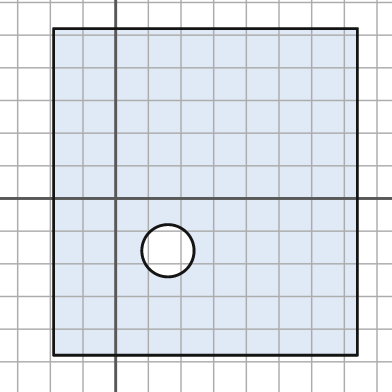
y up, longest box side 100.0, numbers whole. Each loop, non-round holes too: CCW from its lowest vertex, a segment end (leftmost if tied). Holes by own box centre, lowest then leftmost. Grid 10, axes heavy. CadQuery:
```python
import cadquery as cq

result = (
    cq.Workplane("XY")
    .moveTo(-19.0, -48.0)
    .lineTo(74.0, -48.0)
    .lineTo(74.0, 52.0)
    .lineTo(-19.0, 52.0)
    .close()
    .moveTo(16.0, -16.0)
    .circle(8.0)
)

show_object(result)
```